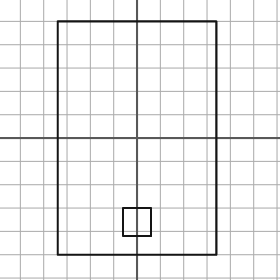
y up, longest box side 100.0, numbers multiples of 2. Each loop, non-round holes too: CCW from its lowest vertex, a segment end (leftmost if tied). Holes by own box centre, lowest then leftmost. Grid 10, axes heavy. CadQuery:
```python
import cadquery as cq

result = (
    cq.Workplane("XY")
    .moveTo(-34.0, -50.0)
    .lineTo(34.0, -50.0)
    .lineTo(34.0, 50.0)
    .lineTo(-34.0, 50.0)
    .close()
    .moveTo(-6.0, -42.0)
    .lineTo(6.0, -42.0)
    .lineTo(6.0, -30.0)
    .lineTo(-6.0, -30.0)
    .close()
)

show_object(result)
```